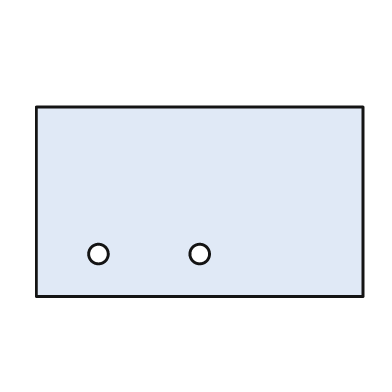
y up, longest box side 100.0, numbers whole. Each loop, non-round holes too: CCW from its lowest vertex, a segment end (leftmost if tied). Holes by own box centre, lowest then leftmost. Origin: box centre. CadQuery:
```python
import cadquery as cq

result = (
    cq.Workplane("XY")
    .moveTo(-50.0, -29.0)
    .lineTo(50.0, -29.0)
    .lineTo(50.0, 29.0)
    .lineTo(-50.0, 29.0)
    .close()
    .moveTo(-31.0, -16.0)
    .circle(3.0)
    .moveTo(0.0, -16.0)
    .circle(3.0)
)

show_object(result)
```